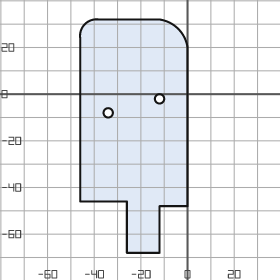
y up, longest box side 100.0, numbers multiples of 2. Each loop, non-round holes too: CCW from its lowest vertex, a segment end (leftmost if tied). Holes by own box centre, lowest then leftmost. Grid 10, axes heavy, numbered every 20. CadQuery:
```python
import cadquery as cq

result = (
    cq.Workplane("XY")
    .moveTo(-26.0, -68.0)
    .lineTo(-12.0, -68.0)
    .lineTo(-12.0, -48.0)
    .lineTo(0.0, -48.0)
    .lineTo(0.0, 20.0)
    .threePointArc((-4.0, 28.0), (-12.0, 32.0))
    .lineTo(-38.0, 32.0)
    .threePointArc((-44.0, 30.0), (-46.0, 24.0))
    .lineTo(-46.0, -46.0)
    .lineTo(-26.0, -46.0)
    .close()
    .moveTo(-34.0, -8.0)
    .circle(2.0)
    .moveTo(-12.0, -2.0)
    .circle(2.0)
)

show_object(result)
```